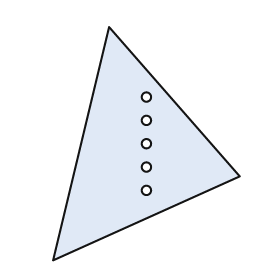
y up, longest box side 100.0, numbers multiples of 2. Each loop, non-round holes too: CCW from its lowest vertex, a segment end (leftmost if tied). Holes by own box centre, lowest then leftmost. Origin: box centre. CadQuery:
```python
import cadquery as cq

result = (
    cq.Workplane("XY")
    .moveTo(-40.0, -50.0)
    .lineTo(40.0, -14.0)
    .lineTo(-16.0, 50.0)
    .close()
    .moveTo(0.0, -20.0)
    .circle(2.0)
    .moveTo(0.0, -10.0)
    .circle(2.0)
    .moveTo(0.0, 0.0)
    .circle(2.0)
    .moveTo(0.0, 10.0)
    .circle(2.0)
    .moveTo(0.0, 20.0)
    .circle(2.0)
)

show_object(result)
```